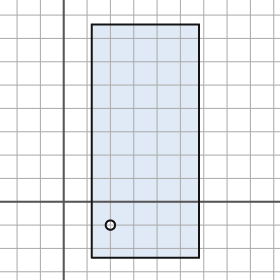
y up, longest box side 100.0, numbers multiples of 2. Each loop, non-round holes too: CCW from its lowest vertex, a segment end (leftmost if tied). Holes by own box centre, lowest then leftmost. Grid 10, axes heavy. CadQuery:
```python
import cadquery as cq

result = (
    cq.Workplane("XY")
    .moveTo(12.0, -24.0)
    .lineTo(58.0, -24.0)
    .lineTo(58.0, 76.0)
    .lineTo(12.0, 76.0)
    .close()
    .moveTo(20.0, -10.0)
    .circle(2.0)
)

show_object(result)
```